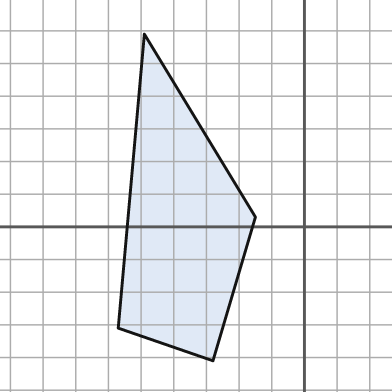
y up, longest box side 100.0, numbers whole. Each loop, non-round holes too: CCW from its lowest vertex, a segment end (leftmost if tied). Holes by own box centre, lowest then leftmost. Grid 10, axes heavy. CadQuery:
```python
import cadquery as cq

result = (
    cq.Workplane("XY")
    .moveTo(-28.0, -41.0)
    .lineTo(-15.0, 3.0)
    .lineTo(-49.0, 59.0)
    .lineTo(-57.0, -31.0)
    .close()
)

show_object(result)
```